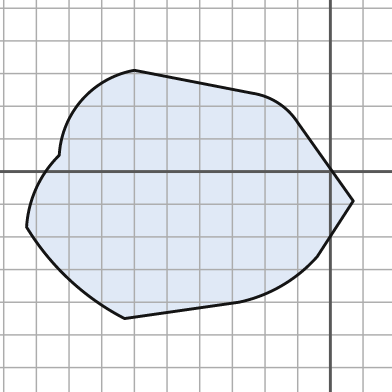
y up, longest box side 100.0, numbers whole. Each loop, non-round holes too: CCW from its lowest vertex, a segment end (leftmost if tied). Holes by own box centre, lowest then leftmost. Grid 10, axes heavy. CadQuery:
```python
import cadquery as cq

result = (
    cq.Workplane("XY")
    .moveTo(-63.0, -45.0)
    .lineTo(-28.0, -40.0)
    .threePointArc((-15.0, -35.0), (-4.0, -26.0))
    .lineTo(7.0, -9.0)
    .lineTo(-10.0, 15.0)
    .threePointArc((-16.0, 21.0), (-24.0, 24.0))
    .lineTo(-60.0, 31.0)
    .threePointArc((-76.0, 22.0), (-83.0, 5.0))
    .threePointArc((-90.0, -5.0), (-93.0, -17.0))
    .threePointArc((-80.0, -33.0), (-63.0, -45.0))
    .close()
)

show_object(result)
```